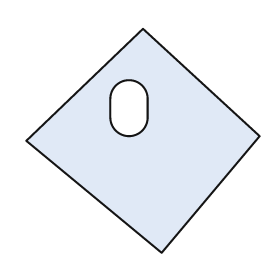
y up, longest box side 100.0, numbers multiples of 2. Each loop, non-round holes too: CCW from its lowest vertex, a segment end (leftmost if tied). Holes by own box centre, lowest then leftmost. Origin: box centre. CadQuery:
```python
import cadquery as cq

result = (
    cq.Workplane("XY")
    .moveTo(8.0, -48.0)
    .lineTo(50.0, 2.0)
    .lineTo(0.0, 48.0)
    .lineTo(-50.0, 0.0)
    .close()
    .moveTo(-14.0, 10.0)
    .threePointArc((-6.0, 2.0), (2.0, 10.0))
    .lineTo(2.0, 18.0)
    .threePointArc((-6.0, 26.0), (-14.0, 18.0))
    .close()
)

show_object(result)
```